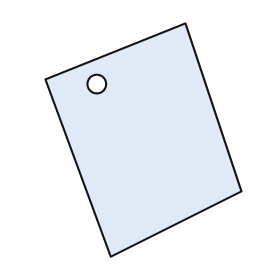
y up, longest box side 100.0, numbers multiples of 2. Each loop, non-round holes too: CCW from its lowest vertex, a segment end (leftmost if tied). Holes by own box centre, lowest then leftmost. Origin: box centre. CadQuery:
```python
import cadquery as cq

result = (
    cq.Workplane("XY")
    .moveTo(-14.0, -50.0)
    .lineTo(42.0, -22.0)
    .lineTo(18.0, 50.0)
    .lineTo(-42.0, 26.0)
    .close()
    .moveTo(-20.0, 24.0)
    .circle(4.0)
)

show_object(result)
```